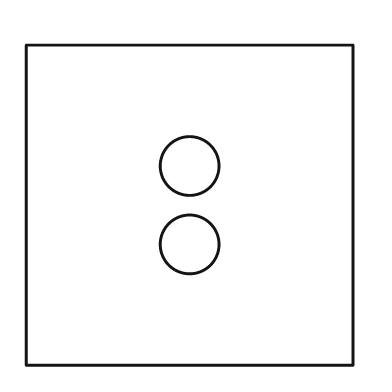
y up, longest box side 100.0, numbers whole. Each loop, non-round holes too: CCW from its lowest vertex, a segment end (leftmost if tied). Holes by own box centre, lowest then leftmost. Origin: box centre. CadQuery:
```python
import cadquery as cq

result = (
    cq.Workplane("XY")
    .moveTo(-50.0, -49.0)
    .lineTo(50.0, -49.0)
    .lineTo(50.0, 49.0)
    .lineTo(-50.0, 49.0)
    .close()
    .moveTo(0.0, -12.0)
    .circle(9.0)
    .moveTo(0.0, 12.0)
    .circle(9.0)
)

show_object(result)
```